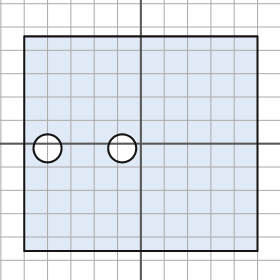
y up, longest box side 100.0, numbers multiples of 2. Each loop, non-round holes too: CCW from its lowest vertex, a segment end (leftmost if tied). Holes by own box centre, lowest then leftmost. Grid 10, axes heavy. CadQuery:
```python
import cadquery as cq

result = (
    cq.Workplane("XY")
    .moveTo(-50.0, -46.0)
    .lineTo(50.0, -46.0)
    .lineTo(50.0, 46.0)
    .lineTo(-50.0, 46.0)
    .close()
    .moveTo(-40.0, -2.0)
    .circle(6.0)
    .moveTo(-8.0, -2.0)
    .circle(6.0)
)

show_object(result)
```